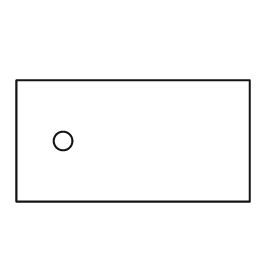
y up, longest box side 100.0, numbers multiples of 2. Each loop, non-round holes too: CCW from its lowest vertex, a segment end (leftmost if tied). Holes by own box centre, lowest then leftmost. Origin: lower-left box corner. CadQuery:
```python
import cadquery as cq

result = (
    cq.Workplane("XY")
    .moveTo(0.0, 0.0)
    .lineTo(100.0, 0.0)
    .lineTo(100.0, 52.0)
    .lineTo(0.0, 52.0)
    .close()
    .moveTo(20.0, 26.0)
    .circle(4.0)
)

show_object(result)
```